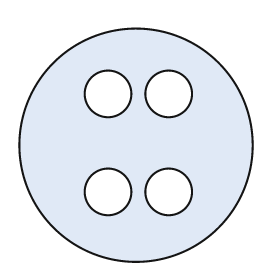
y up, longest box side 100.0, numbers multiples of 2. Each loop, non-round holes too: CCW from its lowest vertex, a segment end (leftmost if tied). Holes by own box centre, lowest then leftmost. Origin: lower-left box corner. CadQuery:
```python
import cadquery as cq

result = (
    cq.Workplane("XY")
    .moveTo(50.0, 50.0)
    .circle(50.0)
    .moveTo(38.0, 30.0)
    .circle(10.0)
    .moveTo(64.0, 30.0)
    .circle(10.0)
    .moveTo(38.0, 72.0)
    .circle(10.0)
    .moveTo(64.0, 72.0)
    .circle(10.0)
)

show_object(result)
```